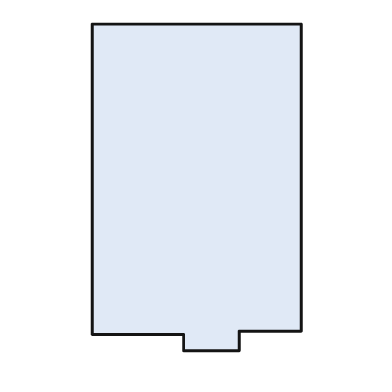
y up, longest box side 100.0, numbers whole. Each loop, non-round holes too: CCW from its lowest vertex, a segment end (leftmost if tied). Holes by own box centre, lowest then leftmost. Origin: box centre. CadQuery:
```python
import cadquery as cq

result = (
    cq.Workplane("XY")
    .moveTo(-4.0, -50.0)
    .lineTo(13.0, -50.0)
    .lineTo(13.0, -44.0)
    .lineTo(32.0, -44.0)
    .lineTo(32.0, 50.0)
    .lineTo(-32.0, 50.0)
    .lineTo(-32.0, -45.0)
    .lineTo(-4.0, -45.0)
    .close()
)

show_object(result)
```